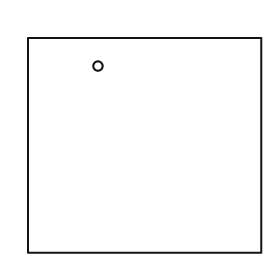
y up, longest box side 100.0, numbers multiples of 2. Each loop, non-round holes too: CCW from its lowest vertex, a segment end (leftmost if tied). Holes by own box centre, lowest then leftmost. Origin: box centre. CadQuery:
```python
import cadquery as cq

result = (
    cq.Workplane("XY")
    .moveTo(-50.0, -46.0)
    .lineTo(50.0, -46.0)
    .lineTo(50.0, 46.0)
    .lineTo(-50.0, 46.0)
    .close()
    .moveTo(-20.0, 34.0)
    .circle(2.0)
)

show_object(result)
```